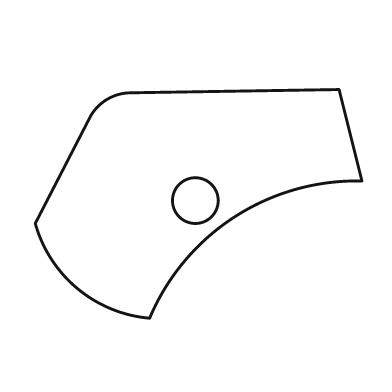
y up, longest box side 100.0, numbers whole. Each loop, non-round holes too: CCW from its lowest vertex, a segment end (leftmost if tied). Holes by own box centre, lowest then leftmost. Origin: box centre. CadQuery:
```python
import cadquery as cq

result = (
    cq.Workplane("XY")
    .moveTo(-15.0, -35.0)
    .threePointArc((11.0, -4.0), (50.0, 7.0))
    .lineTo(43.0, 35.0)
    .lineTo(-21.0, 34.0)
    .threePointArc((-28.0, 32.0), (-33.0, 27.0))
    .lineTo(-50.0, -6.0)
    .threePointArc((-37.0, -26.0), (-15.0, -35.0))
    .close()
    .moveTo(-1.0, 1.0)
    .circle(7.0)
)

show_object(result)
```